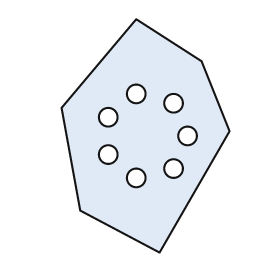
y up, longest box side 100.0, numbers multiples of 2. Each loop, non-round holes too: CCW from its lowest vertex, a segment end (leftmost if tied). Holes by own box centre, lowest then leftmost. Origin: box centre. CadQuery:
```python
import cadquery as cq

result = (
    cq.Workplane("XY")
    .moveTo(6.0, -50.0)
    .lineTo(36.0, 2.0)
    .lineTo(24.0, 32.0)
    .lineTo(-4.0, 50.0)
    .lineTo(-36.0, 12.0)
    .lineTo(-28.0, -32.0)
    .close()
    .moveTo(-4.0, -18.0)
    .circle(4.0)
    .moveTo(12.0, -14.0)
    .circle(4.0)
    .moveTo(-16.0, -8.0)
    .circle(4.0)
    .moveTo(18.0, 0.0)
    .circle(4.0)
    .moveTo(-16.0, 8.0)
    .circle(4.0)
    .moveTo(12.0, 14.0)
    .circle(4.0)
    .moveTo(-4.0, 18.0)
    .circle(4.0)
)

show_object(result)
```